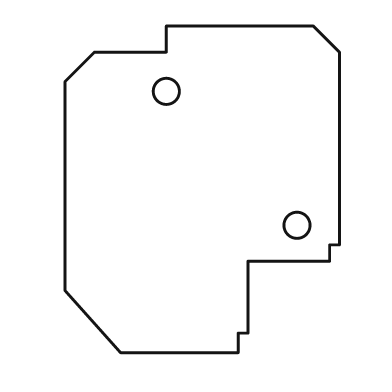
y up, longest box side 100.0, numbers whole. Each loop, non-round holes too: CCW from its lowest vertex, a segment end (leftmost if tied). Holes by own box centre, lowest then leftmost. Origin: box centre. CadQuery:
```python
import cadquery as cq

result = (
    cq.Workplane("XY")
    .moveTo(-25.0, -50.0)
    .lineTo(11.0, -50.0)
    .lineTo(11.0, -44.0)
    .lineTo(14.0, -44.0)
    .lineTo(14.0, -22.0)
    .lineTo(39.0, -22.0)
    .lineTo(39.0, -17.0)
    .lineTo(42.0, -17.0)
    .lineTo(42.0, 42.0)
    .lineTo(34.0, 50.0)
    .lineTo(-11.0, 50.0)
    .lineTo(-11.0, 42.0)
    .lineTo(-33.0, 42.0)
    .lineTo(-42.0, 33.0)
    .lineTo(-42.0, -31.0)
    .close()
    .moveTo(29.0, -11.0)
    .circle(4.0)
    .moveTo(-11.0, 30.0)
    .circle(4.0)
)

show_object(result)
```